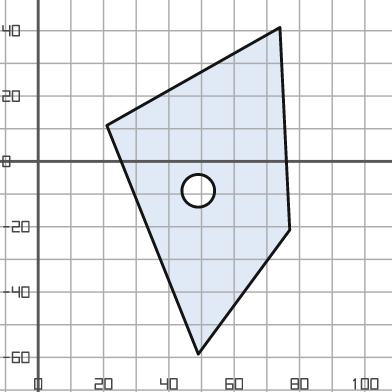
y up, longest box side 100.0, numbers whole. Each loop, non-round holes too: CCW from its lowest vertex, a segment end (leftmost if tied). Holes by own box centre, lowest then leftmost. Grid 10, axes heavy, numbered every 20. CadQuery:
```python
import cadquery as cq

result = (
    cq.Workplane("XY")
    .moveTo(49.0, -59.0)
    .lineTo(77.0, -21.0)
    .lineTo(74.0, 41.0)
    .lineTo(21.0, 11.0)
    .close()
    .moveTo(49.0, -9.0)
    .circle(5.0)
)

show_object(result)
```